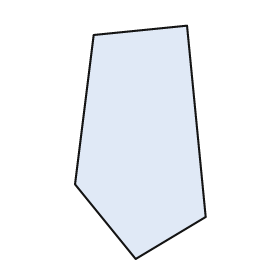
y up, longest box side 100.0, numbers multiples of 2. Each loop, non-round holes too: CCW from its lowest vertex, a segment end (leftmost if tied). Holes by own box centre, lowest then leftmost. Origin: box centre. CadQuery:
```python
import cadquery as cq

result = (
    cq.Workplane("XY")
    .moveTo(-2.0, -50.0)
    .lineTo(28.0, -32.0)
    .lineTo(20.0, 50.0)
    .lineTo(-20.0, 46.0)
    .lineTo(-28.0, -18.0)
    .close()
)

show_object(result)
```